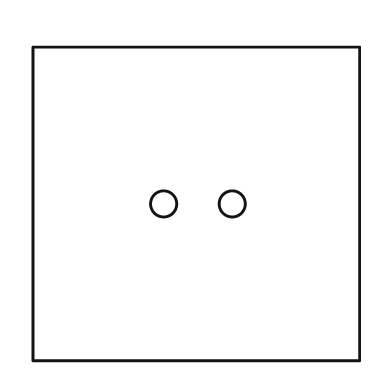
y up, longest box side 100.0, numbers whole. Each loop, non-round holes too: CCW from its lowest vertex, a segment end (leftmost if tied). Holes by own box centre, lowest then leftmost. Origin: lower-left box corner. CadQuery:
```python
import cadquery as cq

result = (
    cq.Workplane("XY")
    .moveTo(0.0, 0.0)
    .lineTo(100.0, 0.0)
    .lineTo(100.0, 96.0)
    .lineTo(0.0, 96.0)
    .close()
    .moveTo(40.0, 48.0)
    .circle(4.0)
    .moveTo(61.0, 48.0)
    .circle(4.0)
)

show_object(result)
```